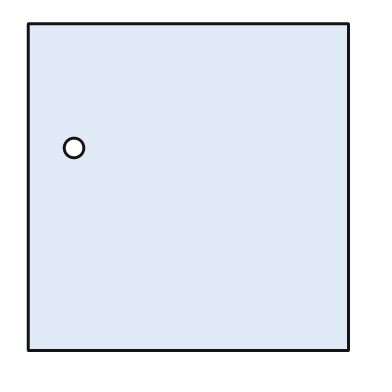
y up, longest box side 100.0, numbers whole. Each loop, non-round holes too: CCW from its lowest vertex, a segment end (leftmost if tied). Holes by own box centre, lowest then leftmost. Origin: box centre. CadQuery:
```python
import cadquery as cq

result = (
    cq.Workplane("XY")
    .moveTo(-49.0, -50.0)
    .lineTo(49.0, -50.0)
    .lineTo(49.0, 50.0)
    .lineTo(-49.0, 50.0)
    .close()
    .moveTo(-35.0, 12.0)
    .circle(3.0)
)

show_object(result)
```